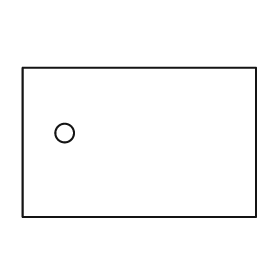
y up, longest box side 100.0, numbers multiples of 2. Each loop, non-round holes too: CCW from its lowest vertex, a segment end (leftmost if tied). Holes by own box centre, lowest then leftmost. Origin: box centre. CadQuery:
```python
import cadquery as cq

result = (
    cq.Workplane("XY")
    .moveTo(-50.0, -32.0)
    .lineTo(50.0, -32.0)
    .lineTo(50.0, 32.0)
    .lineTo(-50.0, 32.0)
    .close()
    .moveTo(-32.0, 4.0)
    .circle(4.0)
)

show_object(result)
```